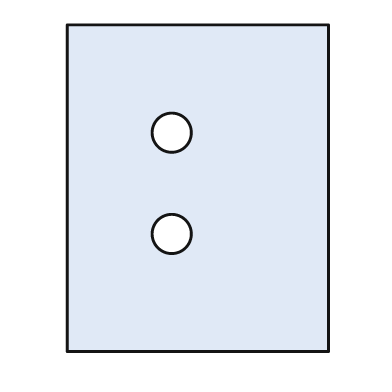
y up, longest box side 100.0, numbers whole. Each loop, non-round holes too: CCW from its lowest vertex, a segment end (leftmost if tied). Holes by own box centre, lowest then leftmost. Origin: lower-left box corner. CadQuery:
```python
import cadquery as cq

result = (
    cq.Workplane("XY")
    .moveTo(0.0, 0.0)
    .lineTo(80.0, 0.0)
    .lineTo(80.0, 100.0)
    .lineTo(0.0, 100.0)
    .close()
    .moveTo(32.0, 36.0)
    .circle(6.0)
    .moveTo(32.0, 67.0)
    .circle(6.0)
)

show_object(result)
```